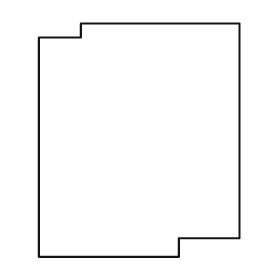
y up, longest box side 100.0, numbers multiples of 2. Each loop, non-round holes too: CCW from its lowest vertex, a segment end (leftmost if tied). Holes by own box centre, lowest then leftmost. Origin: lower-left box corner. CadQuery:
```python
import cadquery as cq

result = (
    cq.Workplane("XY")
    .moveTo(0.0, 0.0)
    .lineTo(60.0, 0.0)
    .lineTo(60.0, 8.0)
    .lineTo(86.0, 8.0)
    .lineTo(86.0, 100.0)
    .lineTo(18.0, 100.0)
    .lineTo(18.0, 94.0)
    .lineTo(0.0, 94.0)
    .close()
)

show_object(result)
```